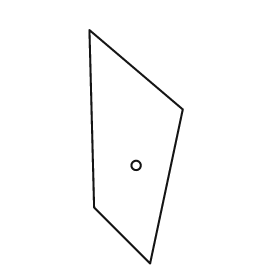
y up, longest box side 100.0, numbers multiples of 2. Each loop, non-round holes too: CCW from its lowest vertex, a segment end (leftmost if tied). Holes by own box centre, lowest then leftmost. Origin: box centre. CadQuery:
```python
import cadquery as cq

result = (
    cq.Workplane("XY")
    .moveTo(6.0, -50.0)
    .lineTo(20.0, 16.0)
    .lineTo(-20.0, 50.0)
    .lineTo(-18.0, -26.0)
    .close()
    .moveTo(0.0, -8.0)
    .circle(2.0)
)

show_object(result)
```